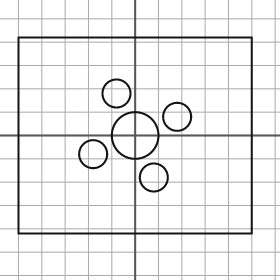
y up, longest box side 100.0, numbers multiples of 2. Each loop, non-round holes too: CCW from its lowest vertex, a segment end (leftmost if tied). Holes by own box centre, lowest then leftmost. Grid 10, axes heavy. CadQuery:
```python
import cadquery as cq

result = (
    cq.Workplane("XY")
    .moveTo(-50.0, -42.0)
    .lineTo(50.0, -42.0)
    .lineTo(50.0, 42.0)
    .lineTo(-50.0, 42.0)
    .close()
    .moveTo(8.0, -18.0)
    .circle(6.0)
    .moveTo(-18.0, -8.0)
    .circle(6.0)
    .moveTo(0.0, 0.0)
    .circle(10.0)
    .moveTo(18.0, 8.0)
    .circle(6.0)
    .moveTo(-8.0, 18.0)
    .circle(6.0)
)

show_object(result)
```